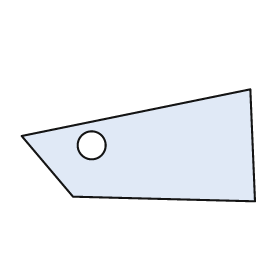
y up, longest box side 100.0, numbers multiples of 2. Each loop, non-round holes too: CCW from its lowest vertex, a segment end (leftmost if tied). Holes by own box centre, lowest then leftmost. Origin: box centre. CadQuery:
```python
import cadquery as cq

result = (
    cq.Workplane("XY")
    .moveTo(50.0, -24.0)
    .lineTo(48.0, 24.0)
    .lineTo(-50.0, 4.0)
    .lineTo(-28.0, -22.0)
    .close()
    .moveTo(-20.0, 0.0)
    .circle(6.0)
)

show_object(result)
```